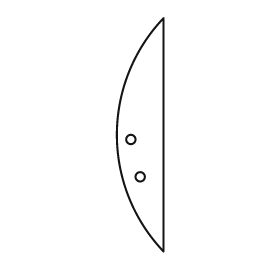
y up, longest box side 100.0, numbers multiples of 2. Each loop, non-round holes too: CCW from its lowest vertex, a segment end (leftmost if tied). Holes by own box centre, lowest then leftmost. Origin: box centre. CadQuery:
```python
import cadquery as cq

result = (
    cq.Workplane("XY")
    .moveTo(10.0, -50.0)
    .lineTo(10.0, 50.0)
    .threePointArc((-10.0, 0.0), (10.0, -50.0))
    .close()
    .moveTo(0.0, -18.0)
    .circle(2.0)
    .moveTo(-4.0, -2.0)
    .circle(2.0)
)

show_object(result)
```